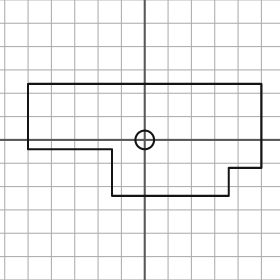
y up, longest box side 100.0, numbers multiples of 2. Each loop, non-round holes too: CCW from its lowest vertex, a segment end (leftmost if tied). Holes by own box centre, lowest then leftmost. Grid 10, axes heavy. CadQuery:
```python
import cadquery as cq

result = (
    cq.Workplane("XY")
    .moveTo(-14.0, -24.0)
    .lineTo(36.0, -24.0)
    .lineTo(36.0, -12.0)
    .lineTo(50.0, -12.0)
    .lineTo(50.0, 24.0)
    .lineTo(-50.0, 24.0)
    .lineTo(-50.0, -4.0)
    .lineTo(-14.0, -4.0)
    .close()
    .moveTo(0.0, 0.0)
    .circle(4.0)
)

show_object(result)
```